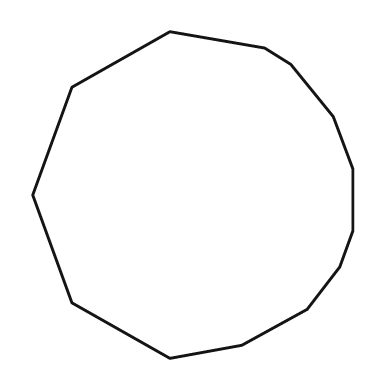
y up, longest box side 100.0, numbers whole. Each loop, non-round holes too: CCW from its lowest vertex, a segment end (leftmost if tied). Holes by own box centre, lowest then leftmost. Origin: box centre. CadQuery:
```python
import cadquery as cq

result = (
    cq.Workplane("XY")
    .moveTo(-7.0, -50.0)
    .lineTo(15.0, -46.0)
    .lineTo(35.0, -35.0)
    .lineTo(45.0, -22.0)
    .lineTo(49.0, -11.0)
    .lineTo(49.0, 8.0)
    .lineTo(43.0, 24.0)
    .lineTo(30.0, 40.0)
    .lineTo(22.0, 45.0)
    .lineTo(-7.0, 50.0)
    .lineTo(-37.0, 33.0)
    .lineTo(-49.0, 0.0)
    .lineTo(-37.0, -33.0)
    .close()
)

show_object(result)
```